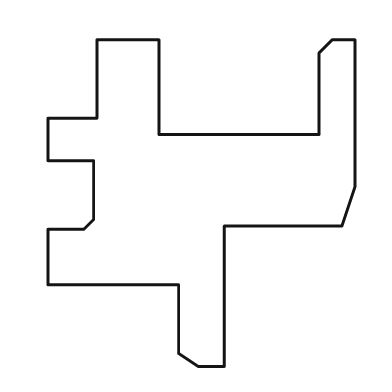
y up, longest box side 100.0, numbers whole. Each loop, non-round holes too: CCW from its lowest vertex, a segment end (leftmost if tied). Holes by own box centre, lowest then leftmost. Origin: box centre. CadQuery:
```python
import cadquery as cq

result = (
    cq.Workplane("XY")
    .moveTo(-1.0, -50.0)
    .lineTo(7.0, -50.0)
    .lineTo(7.0, -7.0)
    .lineTo(43.0, -7.0)
    .lineTo(47.0, 5.0)
    .lineTo(47.0, 50.0)
    .lineTo(40.0, 50.0)
    .lineTo(36.0, 46.0)
    .lineTo(36.0, 21.0)
    .lineTo(-13.0, 21.0)
    .lineTo(-13.0, 50.0)
    .lineTo(-32.0, 50.0)
    .lineTo(-32.0, 26.0)
    .lineTo(-47.0, 26.0)
    .lineTo(-47.0, 13.0)
    .lineTo(-33.0, 13.0)
    .lineTo(-33.0, -5.0)
    .lineTo(-36.0, -8.0)
    .lineTo(-47.0, -8.0)
    .lineTo(-47.0, -25.0)
    .lineTo(-7.0, -25.0)
    .lineTo(-7.0, -46.0)
    .close()
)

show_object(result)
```